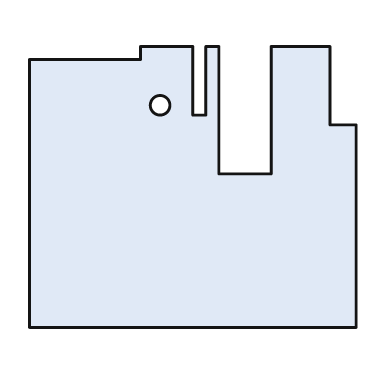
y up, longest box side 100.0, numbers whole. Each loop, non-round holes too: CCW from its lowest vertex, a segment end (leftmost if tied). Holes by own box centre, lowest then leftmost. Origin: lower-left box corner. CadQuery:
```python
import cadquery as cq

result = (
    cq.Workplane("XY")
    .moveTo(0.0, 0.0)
    .lineTo(100.0, 0.0)
    .lineTo(100.0, 62.0)
    .lineTo(92.0, 62.0)
    .lineTo(92.0, 86.0)
    .lineTo(74.0, 86.0)
    .lineTo(74.0, 47.0)
    .lineTo(58.0, 47.0)
    .lineTo(58.0, 86.0)
    .lineTo(54.0, 86.0)
    .lineTo(54.0, 65.0)
    .lineTo(50.0, 65.0)
    .lineTo(50.0, 86.0)
    .lineTo(34.0, 86.0)
    .lineTo(34.0, 82.0)
    .lineTo(0.0, 82.0)
    .close()
    .moveTo(40.0, 68.0)
    .circle(3.0)
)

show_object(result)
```